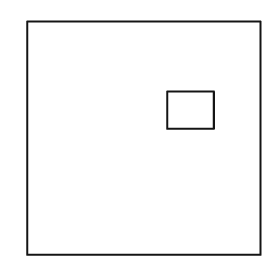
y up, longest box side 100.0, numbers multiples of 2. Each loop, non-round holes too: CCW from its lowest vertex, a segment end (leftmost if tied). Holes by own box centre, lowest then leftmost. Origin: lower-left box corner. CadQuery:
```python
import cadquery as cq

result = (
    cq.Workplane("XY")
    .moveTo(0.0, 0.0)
    .lineTo(100.0, 0.0)
    .lineTo(100.0, 100.0)
    .lineTo(0.0, 100.0)
    .close()
    .moveTo(60.0, 54.0)
    .lineTo(80.0, 54.0)
    .lineTo(80.0, 70.0)
    .lineTo(60.0, 70.0)
    .close()
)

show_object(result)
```